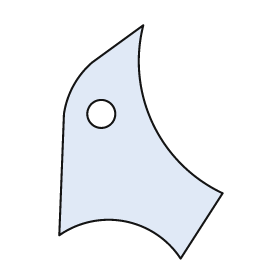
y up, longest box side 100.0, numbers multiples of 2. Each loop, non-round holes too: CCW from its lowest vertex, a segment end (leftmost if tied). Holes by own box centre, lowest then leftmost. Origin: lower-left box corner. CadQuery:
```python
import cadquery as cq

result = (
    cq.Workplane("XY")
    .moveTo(52.0, 0.0)
    .lineTo(70.0, 28.0)
    .threePointArc((40.0, 58.0), (36.0, 100.0))
    .lineTo(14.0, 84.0)
    .threePointArc((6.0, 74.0), (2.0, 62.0))
    .lineTo(0.0, 10.0)
    .threePointArc((28.0, 16.0), (52.0, 0.0))
    .close()
    .moveTo(18.0, 62.0)
    .circle(6.0)
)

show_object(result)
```